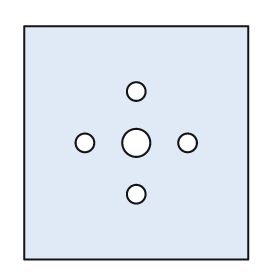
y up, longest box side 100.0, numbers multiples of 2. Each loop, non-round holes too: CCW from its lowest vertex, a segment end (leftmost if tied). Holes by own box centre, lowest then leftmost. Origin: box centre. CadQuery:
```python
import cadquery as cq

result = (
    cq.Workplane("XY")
    .moveTo(-48.0, -50.0)
    .lineTo(48.0, -50.0)
    .lineTo(48.0, 50.0)
    .lineTo(-48.0, 50.0)
    .close()
    .moveTo(0.0, -22.0)
    .circle(4.0)
    .moveTo(-22.0, 0.0)
    .circle(4.0)
    .moveTo(0.0, 0.0)
    .circle(6.0)
    .moveTo(22.0, 0.0)
    .circle(4.0)
    .moveTo(0.0, 22.0)
    .circle(4.0)
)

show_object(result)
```